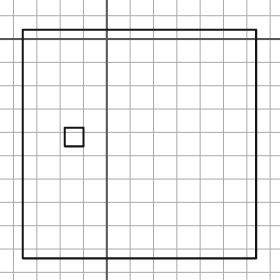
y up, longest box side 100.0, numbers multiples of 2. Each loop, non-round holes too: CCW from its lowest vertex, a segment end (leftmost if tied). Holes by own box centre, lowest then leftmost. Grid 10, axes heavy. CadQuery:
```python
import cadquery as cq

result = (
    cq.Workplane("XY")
    .moveTo(-36.0, -94.0)
    .lineTo(64.0, -94.0)
    .lineTo(64.0, 4.0)
    .lineTo(-36.0, 4.0)
    .close()
    .moveTo(-18.0, -46.0)
    .lineTo(-10.0, -46.0)
    .lineTo(-10.0, -38.0)
    .lineTo(-18.0, -38.0)
    .close()
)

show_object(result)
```